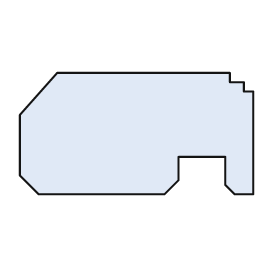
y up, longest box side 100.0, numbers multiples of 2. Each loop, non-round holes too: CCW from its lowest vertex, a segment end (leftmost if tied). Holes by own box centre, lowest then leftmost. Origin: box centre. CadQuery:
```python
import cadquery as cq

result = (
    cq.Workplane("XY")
    .moveTo(-42.0, -26.0)
    .lineTo(12.0, -26.0)
    .lineTo(18.0, -20.0)
    .lineTo(18.0, -10.0)
    .lineTo(38.0, -10.0)
    .lineTo(38.0, -22.0)
    .lineTo(42.0, -26.0)
    .lineTo(50.0, -26.0)
    .lineTo(50.0, 18.0)
    .lineTo(46.0, 18.0)
    .lineTo(46.0, 22.0)
    .lineTo(40.0, 22.0)
    .lineTo(40.0, 26.0)
    .lineTo(-34.0, 26.0)
    .lineTo(-50.0, 8.0)
    .lineTo(-50.0, -18.0)
    .close()
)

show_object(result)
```